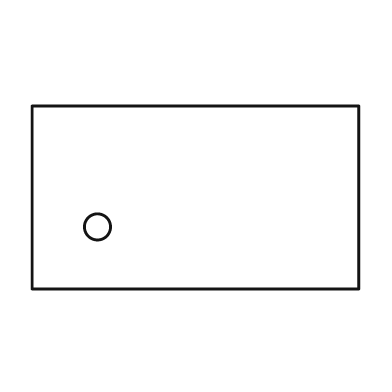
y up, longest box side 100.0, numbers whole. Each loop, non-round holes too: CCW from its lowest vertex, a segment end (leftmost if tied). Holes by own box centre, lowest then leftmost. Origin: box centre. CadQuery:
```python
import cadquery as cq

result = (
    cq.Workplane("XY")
    .moveTo(-50.0, -28.0)
    .lineTo(50.0, -28.0)
    .lineTo(50.0, 28.0)
    .lineTo(-50.0, 28.0)
    .close()
    .moveTo(-30.0, -9.0)
    .circle(4.0)
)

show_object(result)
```